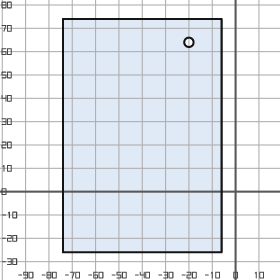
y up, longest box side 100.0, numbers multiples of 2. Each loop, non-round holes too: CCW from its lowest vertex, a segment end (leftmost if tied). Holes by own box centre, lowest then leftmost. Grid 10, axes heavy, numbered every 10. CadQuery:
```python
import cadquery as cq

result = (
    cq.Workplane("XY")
    .moveTo(-74.0, -26.0)
    .lineTo(-6.0, -26.0)
    .lineTo(-6.0, 74.0)
    .lineTo(-74.0, 74.0)
    .close()
    .moveTo(-20.0, 64.0)
    .circle(2.0)
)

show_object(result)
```